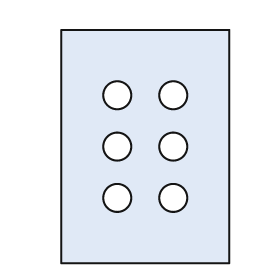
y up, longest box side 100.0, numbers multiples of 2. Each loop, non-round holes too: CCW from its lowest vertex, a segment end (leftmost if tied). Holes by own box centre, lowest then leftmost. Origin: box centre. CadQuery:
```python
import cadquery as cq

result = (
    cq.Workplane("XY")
    .moveTo(-36.0, -50.0)
    .lineTo(36.0, -50.0)
    .lineTo(36.0, 50.0)
    .lineTo(-36.0, 50.0)
    .close()
    .moveTo(-12.0, -22.0)
    .circle(6.0)
    .moveTo(12.0, -22.0)
    .circle(6.0)
    .moveTo(-12.0, 0.0)
    .circle(6.0)
    .moveTo(12.0, 0.0)
    .circle(6.0)
    .moveTo(-12.0, 22.0)
    .circle(6.0)
    .moveTo(12.0, 22.0)
    .circle(6.0)
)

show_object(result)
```